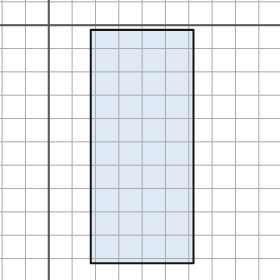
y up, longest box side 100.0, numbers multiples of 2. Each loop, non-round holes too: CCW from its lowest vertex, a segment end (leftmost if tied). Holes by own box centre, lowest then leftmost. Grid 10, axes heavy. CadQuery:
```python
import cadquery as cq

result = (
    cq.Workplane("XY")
    .moveTo(18.0, -102.0)
    .lineTo(62.0, -102.0)
    .lineTo(62.0, -2.0)
    .lineTo(18.0, -2.0)
    .close()
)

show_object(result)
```